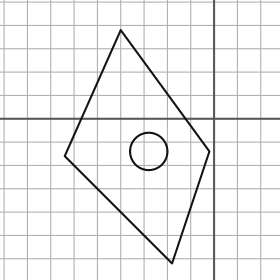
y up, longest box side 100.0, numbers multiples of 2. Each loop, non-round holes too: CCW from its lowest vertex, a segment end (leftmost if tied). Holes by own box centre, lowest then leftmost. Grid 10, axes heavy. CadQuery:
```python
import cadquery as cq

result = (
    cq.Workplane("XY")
    .moveTo(-18.0, -62.0)
    .lineTo(-2.0, -14.0)
    .lineTo(-40.0, 38.0)
    .lineTo(-64.0, -16.0)
    .close()
    .moveTo(-28.0, -14.0)
    .circle(8.0)
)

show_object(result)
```